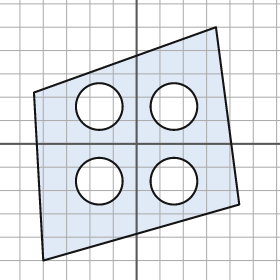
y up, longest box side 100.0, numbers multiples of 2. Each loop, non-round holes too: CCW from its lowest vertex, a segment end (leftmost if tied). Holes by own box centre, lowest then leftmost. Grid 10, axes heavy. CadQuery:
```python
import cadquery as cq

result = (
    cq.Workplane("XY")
    .moveTo(-40.0, -50.0)
    .lineTo(44.0, -26.0)
    .lineTo(34.0, 50.0)
    .lineTo(-44.0, 22.0)
    .close()
    .moveTo(-16.0, -16.0)
    .circle(10.0)
    .moveTo(16.0, -16.0)
    .circle(10.0)
    .moveTo(-16.0, 16.0)
    .circle(10.0)
    .moveTo(16.0, 16.0)
    .circle(10.0)
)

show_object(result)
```